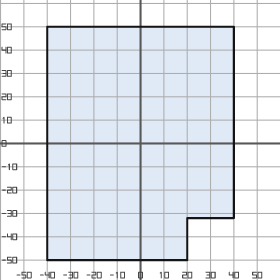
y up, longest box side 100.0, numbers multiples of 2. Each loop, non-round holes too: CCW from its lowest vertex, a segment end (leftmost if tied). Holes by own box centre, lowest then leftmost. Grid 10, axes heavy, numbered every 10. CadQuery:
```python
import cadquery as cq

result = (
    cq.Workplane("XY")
    .moveTo(-40.0, -50.0)
    .lineTo(20.0, -50.0)
    .lineTo(20.0, -32.0)
    .lineTo(40.0, -32.0)
    .lineTo(40.0, 50.0)
    .lineTo(-40.0, 50.0)
    .close()
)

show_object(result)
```